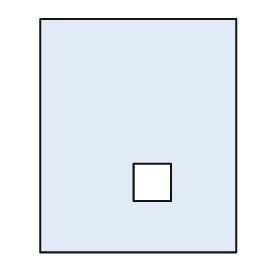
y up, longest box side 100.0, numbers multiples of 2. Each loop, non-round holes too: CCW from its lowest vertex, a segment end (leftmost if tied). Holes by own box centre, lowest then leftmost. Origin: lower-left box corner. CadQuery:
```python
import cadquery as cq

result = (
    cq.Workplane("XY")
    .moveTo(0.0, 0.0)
    .lineTo(84.0, 0.0)
    .lineTo(84.0, 100.0)
    .lineTo(0.0, 100.0)
    .close()
    .moveTo(40.0, 22.0)
    .lineTo(56.0, 22.0)
    .lineTo(56.0, 38.0)
    .lineTo(40.0, 38.0)
    .close()
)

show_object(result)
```